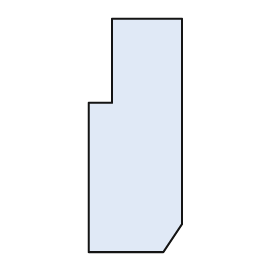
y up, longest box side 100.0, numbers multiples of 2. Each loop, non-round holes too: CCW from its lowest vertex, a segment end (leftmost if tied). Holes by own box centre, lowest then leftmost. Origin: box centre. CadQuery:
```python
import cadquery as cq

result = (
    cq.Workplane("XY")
    .moveTo(-20.0, -50.0)
    .lineTo(12.0, -50.0)
    .lineTo(20.0, -38.0)
    .lineTo(20.0, 50.0)
    .lineTo(-10.0, 50.0)
    .lineTo(-10.0, 14.0)
    .lineTo(-20.0, 14.0)
    .close()
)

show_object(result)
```